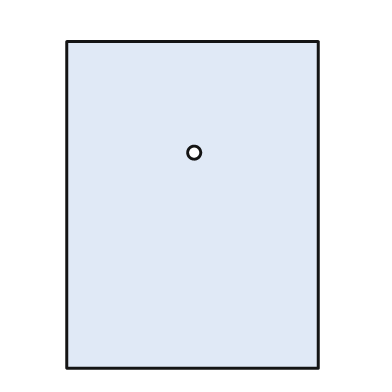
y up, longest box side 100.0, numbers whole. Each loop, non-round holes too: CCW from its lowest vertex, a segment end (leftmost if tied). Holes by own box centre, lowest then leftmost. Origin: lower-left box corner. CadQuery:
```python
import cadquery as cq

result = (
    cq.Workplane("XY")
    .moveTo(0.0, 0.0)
    .lineTo(77.0, 0.0)
    .lineTo(77.0, 100.0)
    .lineTo(0.0, 100.0)
    .close()
    .moveTo(39.0, 66.0)
    .circle(2.0)
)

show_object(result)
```